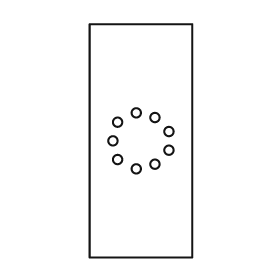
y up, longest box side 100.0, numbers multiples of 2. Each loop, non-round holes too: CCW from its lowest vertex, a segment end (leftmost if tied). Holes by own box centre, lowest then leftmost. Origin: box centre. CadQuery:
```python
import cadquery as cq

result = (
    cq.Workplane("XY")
    .moveTo(-22.0, -50.0)
    .lineTo(22.0, -50.0)
    .lineTo(22.0, 50.0)
    .lineTo(-22.0, 50.0)
    .close()
    .moveTo(-2.0, -12.0)
    .circle(2.0)
    .moveTo(6.0, -10.0)
    .circle(2.0)
    .moveTo(-10.0, -8.0)
    .circle(2.0)
    .moveTo(12.0, -4.0)
    .circle(2.0)
    .moveTo(-12.0, 0.0)
    .circle(2.0)
    .moveTo(12.0, 4.0)
    .circle(2.0)
    .moveTo(-10.0, 8.0)
    .circle(2.0)
    .moveTo(6.0, 10.0)
    .circle(2.0)
    .moveTo(-2.0, 12.0)
    .circle(2.0)
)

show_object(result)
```